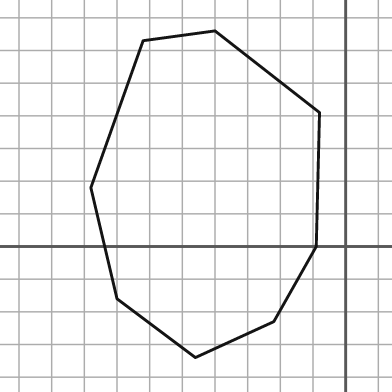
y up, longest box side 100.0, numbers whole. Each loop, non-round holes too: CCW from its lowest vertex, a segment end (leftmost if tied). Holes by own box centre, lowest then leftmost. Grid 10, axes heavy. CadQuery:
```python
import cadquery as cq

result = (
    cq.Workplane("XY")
    .moveTo(-46.0, -34.0)
    .lineTo(-22.0, -23.0)
    .lineTo(-9.0, 0.0)
    .lineTo(-8.0, 41.0)
    .lineTo(-40.0, 66.0)
    .lineTo(-62.0, 63.0)
    .lineTo(-78.0, 18.0)
    .lineTo(-70.0, -16.0)
    .close()
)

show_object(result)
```